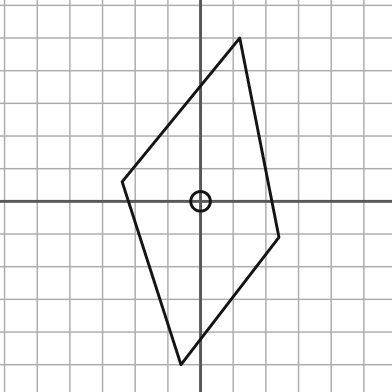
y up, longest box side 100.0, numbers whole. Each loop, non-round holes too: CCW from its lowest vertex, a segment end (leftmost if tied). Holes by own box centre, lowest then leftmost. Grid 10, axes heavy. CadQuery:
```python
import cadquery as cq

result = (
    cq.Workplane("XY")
    .moveTo(-6.0, -50.0)
    .lineTo(24.0, -11.0)
    .lineTo(12.0, 50.0)
    .lineTo(-24.0, 6.0)
    .close()
    .moveTo(0.0, 0.0)
    .circle(3.0)
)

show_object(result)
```